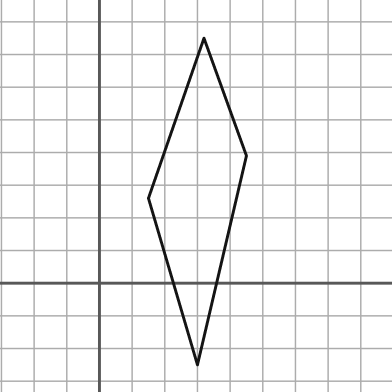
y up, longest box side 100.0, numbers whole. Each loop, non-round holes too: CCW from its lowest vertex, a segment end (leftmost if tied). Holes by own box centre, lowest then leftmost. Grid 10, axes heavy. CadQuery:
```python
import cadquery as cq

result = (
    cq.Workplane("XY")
    .moveTo(30.0, -25.0)
    .lineTo(45.0, 39.0)
    .lineTo(32.0, 75.0)
    .lineTo(15.0, 26.0)
    .close()
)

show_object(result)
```